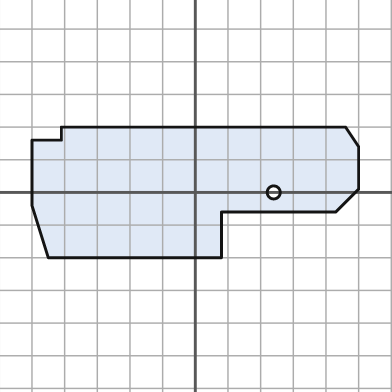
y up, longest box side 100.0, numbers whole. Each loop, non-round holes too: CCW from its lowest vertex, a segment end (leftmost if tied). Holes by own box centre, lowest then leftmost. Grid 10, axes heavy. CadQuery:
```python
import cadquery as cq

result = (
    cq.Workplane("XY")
    .moveTo(-45.0, -20.0)
    .lineTo(8.0, -20.0)
    .lineTo(8.0, -6.0)
    .lineTo(43.0, -6.0)
    .lineTo(50.0, 1.0)
    .lineTo(50.0, 14.0)
    .lineTo(46.0, 20.0)
    .lineTo(-41.0, 20.0)
    .lineTo(-41.0, 16.0)
    .lineTo(-50.0, 16.0)
    .lineTo(-50.0, -4.0)
    .close()
    .moveTo(24.0, 0.0)
    .circle(2.0)
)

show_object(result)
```